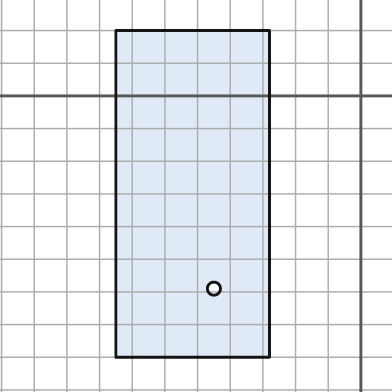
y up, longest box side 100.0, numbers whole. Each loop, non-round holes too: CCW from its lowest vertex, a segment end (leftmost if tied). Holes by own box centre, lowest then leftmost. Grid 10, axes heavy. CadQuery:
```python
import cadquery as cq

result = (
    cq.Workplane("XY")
    .moveTo(-75.0, -80.0)
    .lineTo(-28.0, -80.0)
    .lineTo(-28.0, 20.0)
    .lineTo(-75.0, 20.0)
    .close()
    .moveTo(-45.0, -59.0)
    .circle(2.0)
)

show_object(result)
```